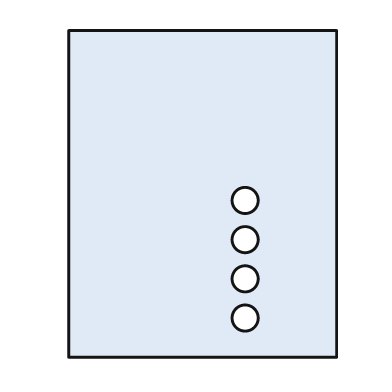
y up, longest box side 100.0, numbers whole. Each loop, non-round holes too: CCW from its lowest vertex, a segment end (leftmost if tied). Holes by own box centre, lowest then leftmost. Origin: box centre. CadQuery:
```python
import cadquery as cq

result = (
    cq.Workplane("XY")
    .moveTo(-41.0, -50.0)
    .lineTo(41.0, -50.0)
    .lineTo(41.0, 50.0)
    .lineTo(-41.0, 50.0)
    .close()
    .moveTo(13.0, -38.0)
    .circle(4.0)
    .moveTo(13.0, -26.0)
    .circle(4.0)
    .moveTo(13.0, -14.0)
    .circle(4.0)
    .moveTo(13.0, -2.0)
    .circle(4.0)
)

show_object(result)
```